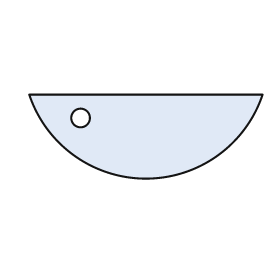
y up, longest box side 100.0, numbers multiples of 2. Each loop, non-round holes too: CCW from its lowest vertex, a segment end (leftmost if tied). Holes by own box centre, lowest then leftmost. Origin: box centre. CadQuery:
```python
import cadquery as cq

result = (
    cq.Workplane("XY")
    .moveTo(-50.0, 18.0)
    .threePointArc((0.0, -18.0), (50.0, 18.0))
    .close()
    .moveTo(-28.0, 8.0)
    .circle(4.0)
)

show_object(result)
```